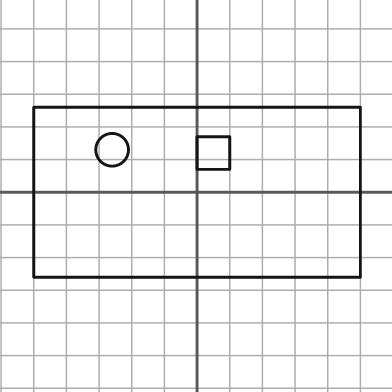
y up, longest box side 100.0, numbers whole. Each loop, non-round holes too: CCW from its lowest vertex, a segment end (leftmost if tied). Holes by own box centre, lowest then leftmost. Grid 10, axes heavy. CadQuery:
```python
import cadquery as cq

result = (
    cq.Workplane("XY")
    .moveTo(-50.0, -26.0)
    .lineTo(50.0, -26.0)
    .lineTo(50.0, 26.0)
    .lineTo(-50.0, 26.0)
    .close()
    .moveTo(0.0, 7.0)
    .lineTo(10.0, 7.0)
    .lineTo(10.0, 17.0)
    .lineTo(0.0, 17.0)
    .close()
    .moveTo(-26.0, 13.0)
    .circle(5.0)
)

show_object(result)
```